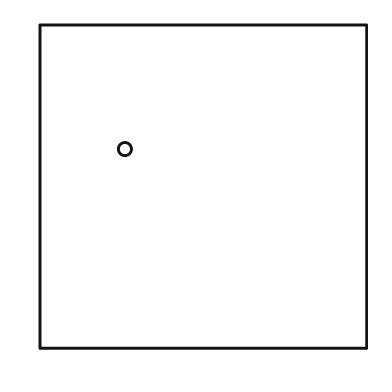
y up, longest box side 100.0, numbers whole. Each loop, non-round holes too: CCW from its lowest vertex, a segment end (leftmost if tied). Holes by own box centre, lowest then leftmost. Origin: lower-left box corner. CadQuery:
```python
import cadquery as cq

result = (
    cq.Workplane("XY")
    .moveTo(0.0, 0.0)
    .lineTo(100.0, 0.0)
    .lineTo(100.0, 99.0)
    .lineTo(0.0, 99.0)
    .close()
    .moveTo(26.0, 61.0)
    .circle(2.0)
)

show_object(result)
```